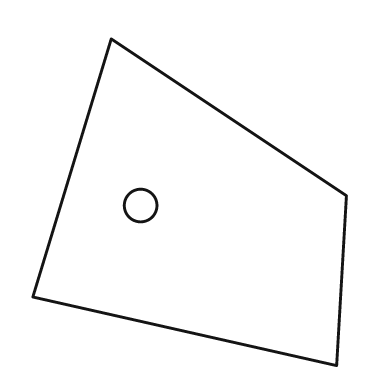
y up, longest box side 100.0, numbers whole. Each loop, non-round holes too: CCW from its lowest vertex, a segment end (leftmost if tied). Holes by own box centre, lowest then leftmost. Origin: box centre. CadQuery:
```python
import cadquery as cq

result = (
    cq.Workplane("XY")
    .moveTo(45.0, -50.0)
    .lineTo(48.0, 2.0)
    .lineTo(-24.0, 50.0)
    .lineTo(-48.0, -29.0)
    .close()
    .moveTo(-15.0, -1.0)
    .circle(5.0)
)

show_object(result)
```